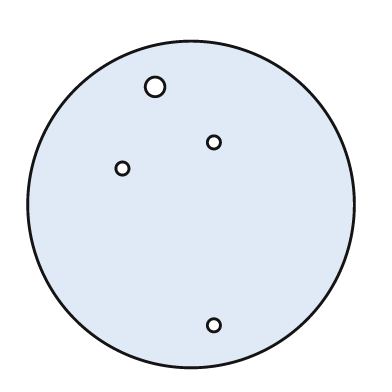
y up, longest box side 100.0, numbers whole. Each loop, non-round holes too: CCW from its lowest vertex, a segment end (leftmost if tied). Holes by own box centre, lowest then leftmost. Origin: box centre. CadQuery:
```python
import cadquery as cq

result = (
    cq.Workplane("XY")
    .moveTo(0.0, 0.0)
    .circle(50.0)
    .moveTo(7.0, -37.0)
    .circle(2.0)
    .moveTo(-21.0, 11.0)
    .circle(2.0)
    .moveTo(7.0, 19.0)
    .circle(2.0)
    .moveTo(-11.0, 36.0)
    .circle(3.0)
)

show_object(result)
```